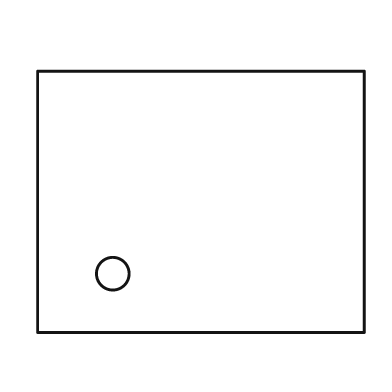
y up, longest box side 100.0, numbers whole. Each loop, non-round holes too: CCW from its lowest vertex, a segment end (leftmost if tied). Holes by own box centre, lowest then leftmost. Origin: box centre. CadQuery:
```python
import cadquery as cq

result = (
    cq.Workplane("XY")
    .moveTo(-50.0, -40.0)
    .lineTo(50.0, -40.0)
    .lineTo(50.0, 40.0)
    .lineTo(-50.0, 40.0)
    .close()
    .moveTo(-27.0, -22.0)
    .circle(5.0)
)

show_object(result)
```